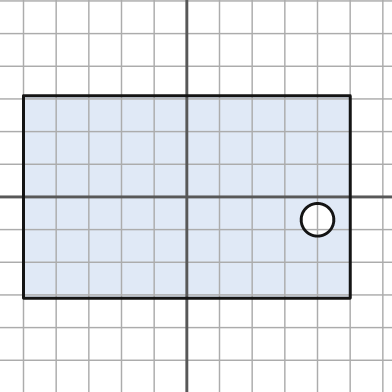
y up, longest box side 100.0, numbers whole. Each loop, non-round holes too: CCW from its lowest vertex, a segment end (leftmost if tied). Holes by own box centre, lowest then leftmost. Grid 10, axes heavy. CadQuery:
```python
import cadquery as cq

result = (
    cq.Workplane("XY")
    .moveTo(-50.0, -31.0)
    .lineTo(50.0, -31.0)
    .lineTo(50.0, 31.0)
    .lineTo(-50.0, 31.0)
    .close()
    .moveTo(40.0, -7.0)
    .circle(5.0)
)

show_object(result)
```